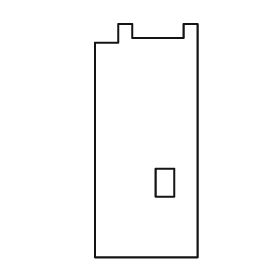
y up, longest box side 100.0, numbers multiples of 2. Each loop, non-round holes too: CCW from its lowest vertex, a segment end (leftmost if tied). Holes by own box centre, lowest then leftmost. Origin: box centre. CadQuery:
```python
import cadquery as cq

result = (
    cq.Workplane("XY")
    .moveTo(-22.0, -50.0)
    .lineTo(22.0, -50.0)
    .lineTo(22.0, 50.0)
    .lineTo(16.0, 50.0)
    .lineTo(16.0, 44.0)
    .lineTo(-6.0, 44.0)
    .lineTo(-6.0, 50.0)
    .lineTo(-12.0, 50.0)
    .lineTo(-12.0, 42.0)
    .lineTo(-22.0, 42.0)
    .close()
    .moveTo(4.0, -24.0)
    .lineTo(12.0, -24.0)
    .lineTo(12.0, -12.0)
    .lineTo(4.0, -12.0)
    .close()
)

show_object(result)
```